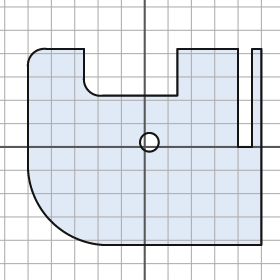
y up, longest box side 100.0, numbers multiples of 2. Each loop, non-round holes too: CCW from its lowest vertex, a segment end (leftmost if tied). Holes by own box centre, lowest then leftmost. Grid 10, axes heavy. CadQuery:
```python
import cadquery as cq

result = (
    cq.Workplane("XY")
    .moveTo(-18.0, -42.0)
    .lineTo(50.0, -42.0)
    .lineTo(50.0, 42.0)
    .lineTo(46.0, 42.0)
    .lineTo(46.0, 0.0)
    .lineTo(40.0, 0.0)
    .lineTo(40.0, 42.0)
    .lineTo(14.0, 42.0)
    .lineTo(14.0, 22.0)
    .lineTo(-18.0, 22.0)
    .threePointArc((-24.0, 24.0), (-26.0, 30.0))
    .lineTo(-26.0, 42.0)
    .lineTo(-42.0, 42.0)
    .threePointArc((-48.0, 40.0), (-50.0, 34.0))
    .lineTo(-50.0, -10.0)
    .threePointArc((-40.0, -32.0), (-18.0, -42.0))
    .close()
    .moveTo(2.0, 2.0)
    .circle(4.0)
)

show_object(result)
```